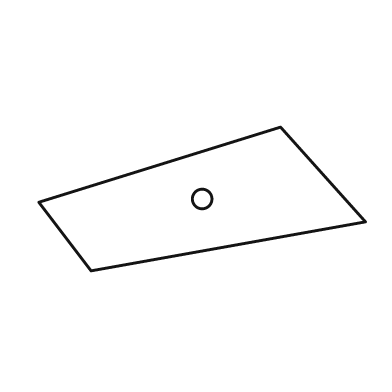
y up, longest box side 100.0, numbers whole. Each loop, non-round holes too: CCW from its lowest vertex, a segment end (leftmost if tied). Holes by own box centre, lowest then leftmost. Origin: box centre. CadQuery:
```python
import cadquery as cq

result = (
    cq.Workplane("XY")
    .moveTo(-34.0, -22.0)
    .lineTo(50.0, -7.0)
    .lineTo(24.0, 22.0)
    .lineTo(-50.0, -1.0)
    .close()
    .moveTo(0.0, 0.0)
    .circle(3.0)
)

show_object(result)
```